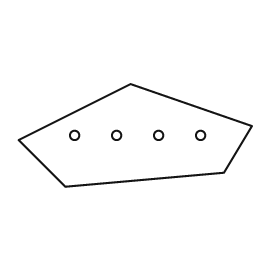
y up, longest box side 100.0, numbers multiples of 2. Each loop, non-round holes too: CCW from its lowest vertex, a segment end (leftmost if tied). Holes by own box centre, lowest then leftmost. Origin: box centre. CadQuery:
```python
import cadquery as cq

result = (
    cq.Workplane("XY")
    .moveTo(-30.0, -22.0)
    .lineTo(38.0, -16.0)
    .lineTo(50.0, 4.0)
    .lineTo(-2.0, 22.0)
    .lineTo(-50.0, -2.0)
    .close()
    .moveTo(-26.0, 0.0)
    .circle(2.0)
    .moveTo(-8.0, 0.0)
    .circle(2.0)
    .moveTo(10.0, 0.0)
    .circle(2.0)
    .moveTo(28.0, 0.0)
    .circle(2.0)
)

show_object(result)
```